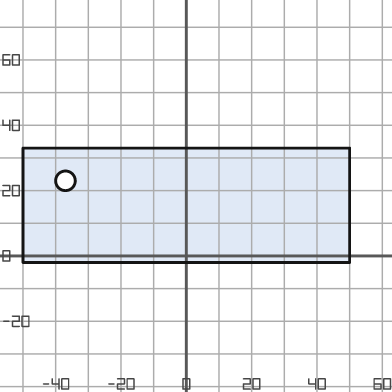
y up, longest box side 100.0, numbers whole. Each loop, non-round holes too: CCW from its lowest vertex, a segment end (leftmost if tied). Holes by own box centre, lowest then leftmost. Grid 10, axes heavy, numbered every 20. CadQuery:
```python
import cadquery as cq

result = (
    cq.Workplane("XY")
    .moveTo(-50.0, -2.0)
    .lineTo(50.0, -2.0)
    .lineTo(50.0, 33.0)
    .lineTo(-50.0, 33.0)
    .close()
    .moveTo(-37.0, 23.0)
    .circle(3.0)
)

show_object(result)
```